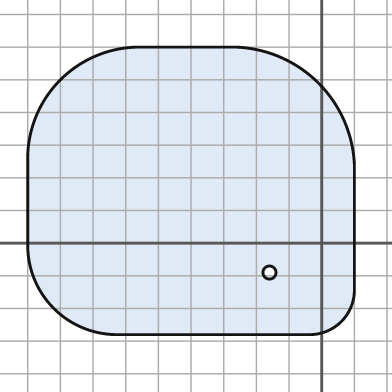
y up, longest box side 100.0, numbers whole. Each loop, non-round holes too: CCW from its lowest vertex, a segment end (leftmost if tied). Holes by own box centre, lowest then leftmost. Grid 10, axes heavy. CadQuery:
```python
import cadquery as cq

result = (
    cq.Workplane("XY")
    .moveTo(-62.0, -28.0)
    .lineTo(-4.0, -28.0)
    .threePointArc((6.0, -24.0), (10.0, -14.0))
    .lineTo(10.0, 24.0)
    .threePointArc((-1.0, 49.0), (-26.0, 60.0))
    .lineTo(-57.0, 60.0)
    .threePointArc((-80.0, 50.0), (-90.0, 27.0))
    .lineTo(-90.0, 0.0)
    .threePointArc((-82.0, -20.0), (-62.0, -28.0))
    .close()
    .moveTo(-16.0, -9.0)
    .circle(2.0)
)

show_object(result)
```